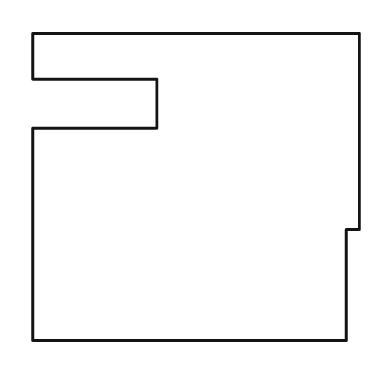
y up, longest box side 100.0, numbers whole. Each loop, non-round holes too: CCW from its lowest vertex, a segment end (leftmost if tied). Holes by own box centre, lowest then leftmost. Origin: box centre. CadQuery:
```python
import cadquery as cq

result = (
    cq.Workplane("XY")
    .moveTo(-50.0, -47.0)
    .lineTo(46.0, -47.0)
    .lineTo(46.0, -13.0)
    .lineTo(50.0, -13.0)
    .lineTo(50.0, 47.0)
    .lineTo(-50.0, 47.0)
    .lineTo(-50.0, 33.0)
    .lineTo(-12.0, 33.0)
    .lineTo(-12.0, 18.0)
    .lineTo(-50.0, 18.0)
    .close()
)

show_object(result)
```